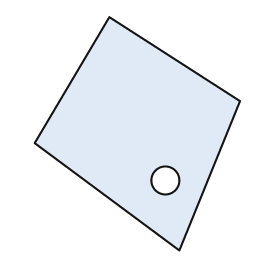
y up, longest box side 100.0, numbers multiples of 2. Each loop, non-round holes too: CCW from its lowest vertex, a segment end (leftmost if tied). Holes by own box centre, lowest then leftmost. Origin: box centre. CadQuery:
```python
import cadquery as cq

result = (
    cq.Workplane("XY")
    .moveTo(18.0, -50.0)
    .lineTo(44.0, 14.0)
    .lineTo(-12.0, 50.0)
    .lineTo(-44.0, -4.0)
    .close()
    .moveTo(12.0, -20.0)
    .circle(6.0)
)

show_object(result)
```